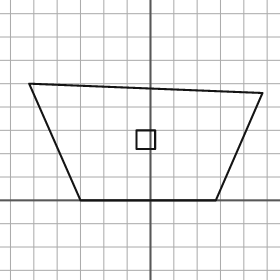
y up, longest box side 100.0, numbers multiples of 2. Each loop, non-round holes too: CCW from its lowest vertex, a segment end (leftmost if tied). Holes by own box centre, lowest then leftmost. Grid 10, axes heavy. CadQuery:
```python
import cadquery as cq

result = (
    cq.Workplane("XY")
    .moveTo(-30.0, 0.0)
    .lineTo(28.0, 0.0)
    .lineTo(48.0, 46.0)
    .lineTo(-52.0, 50.0)
    .close()
    .moveTo(-6.0, 22.0)
    .lineTo(2.0, 22.0)
    .lineTo(2.0, 30.0)
    .lineTo(-6.0, 30.0)
    .close()
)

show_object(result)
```